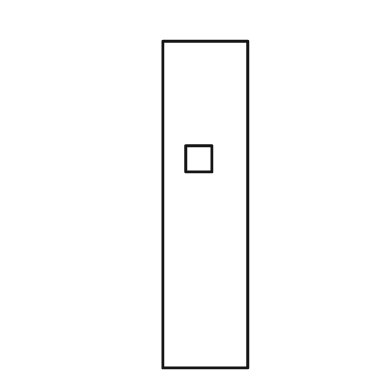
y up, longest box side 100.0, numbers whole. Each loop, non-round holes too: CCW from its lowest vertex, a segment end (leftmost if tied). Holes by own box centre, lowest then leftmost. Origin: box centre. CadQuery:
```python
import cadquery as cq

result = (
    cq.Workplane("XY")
    .moveTo(-13.0, -50.0)
    .lineTo(13.0, -50.0)
    .lineTo(13.0, 50.0)
    .lineTo(-13.0, 50.0)
    .close()
    .moveTo(-6.0, 10.0)
    .lineTo(2.0, 10.0)
    .lineTo(2.0, 18.0)
    .lineTo(-6.0, 18.0)
    .close()
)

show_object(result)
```